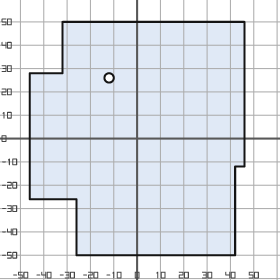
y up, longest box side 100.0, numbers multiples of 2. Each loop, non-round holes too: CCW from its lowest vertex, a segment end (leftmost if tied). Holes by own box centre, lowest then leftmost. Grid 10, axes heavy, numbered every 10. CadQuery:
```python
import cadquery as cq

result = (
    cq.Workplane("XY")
    .moveTo(-26.0, -50.0)
    .lineTo(42.0, -50.0)
    .lineTo(42.0, -12.0)
    .lineTo(46.0, -12.0)
    .lineTo(46.0, 50.0)
    .lineTo(-32.0, 50.0)
    .lineTo(-32.0, 28.0)
    .lineTo(-46.0, 28.0)
    .lineTo(-46.0, -26.0)
    .lineTo(-26.0, -26.0)
    .close()
    .moveTo(-12.0, 26.0)
    .circle(2.0)
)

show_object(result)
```